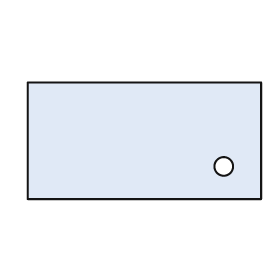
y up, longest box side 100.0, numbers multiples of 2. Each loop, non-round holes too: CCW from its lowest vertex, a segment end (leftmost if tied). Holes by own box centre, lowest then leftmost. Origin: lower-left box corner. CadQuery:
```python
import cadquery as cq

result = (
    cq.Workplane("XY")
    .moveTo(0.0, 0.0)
    .lineTo(100.0, 0.0)
    .lineTo(100.0, 50.0)
    .lineTo(0.0, 50.0)
    .close()
    .moveTo(84.0, 14.0)
    .circle(4.0)
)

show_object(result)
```